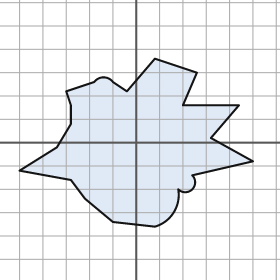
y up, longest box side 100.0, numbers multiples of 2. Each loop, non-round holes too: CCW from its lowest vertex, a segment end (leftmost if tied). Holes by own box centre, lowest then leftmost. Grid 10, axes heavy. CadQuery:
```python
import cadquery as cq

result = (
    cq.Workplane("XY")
    .moveTo(8.0, -36.0)
    .threePointArc((16.0, -30.0), (18.0, -20.0))
    .threePointArc((24.0, -20.0), (24.0, -14.0))
    .lineTo(50.0, -8.0)
    .lineTo(32.0, 2.0)
    .lineTo(44.0, 16.0)
    .lineTo(20.0, 16.0)
    .lineTo(26.0, 30.0)
    .lineTo(8.0, 36.0)
    .lineTo(-4.0, 22.0)
    .lineTo(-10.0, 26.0)
    .threePointArc((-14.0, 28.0), (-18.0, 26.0))
    .lineTo(-30.0, 22.0)
    .lineTo(-28.0, 16.0)
    .lineTo(-28.0, 8.0)
    .lineTo(-34.0, -2.0)
    .lineTo(-50.0, -12.0)
    .lineTo(-28.0, -16.0)
    .lineTo(-22.0, -24.0)
    .lineTo(-10.0, -34.0)
    .close()
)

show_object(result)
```